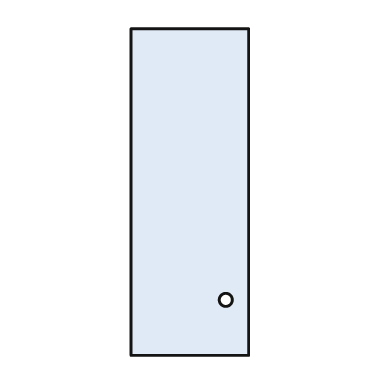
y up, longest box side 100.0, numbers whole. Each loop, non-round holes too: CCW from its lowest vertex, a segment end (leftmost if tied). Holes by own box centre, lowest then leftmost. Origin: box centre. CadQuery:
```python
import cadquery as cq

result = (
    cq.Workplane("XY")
    .moveTo(-18.0, -50.0)
    .lineTo(18.0, -50.0)
    .lineTo(18.0, 50.0)
    .lineTo(-18.0, 50.0)
    .close()
    .moveTo(11.0, -33.0)
    .circle(2.0)
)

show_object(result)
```